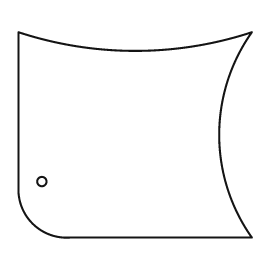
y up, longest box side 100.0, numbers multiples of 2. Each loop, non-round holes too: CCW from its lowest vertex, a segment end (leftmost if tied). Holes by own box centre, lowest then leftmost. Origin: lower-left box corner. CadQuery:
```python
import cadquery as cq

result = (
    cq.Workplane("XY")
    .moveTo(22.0, 0.0)
    .lineTo(100.0, 0.0)
    .threePointArc((86.0, 44.0), (100.0, 88.0))
    .threePointArc((50.0, 80.0), (0.0, 88.0))
    .lineTo(0.0, 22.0)
    .threePointArc((6.0, 6.0), (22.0, 0.0))
    .close()
    .moveTo(10.0, 24.0)
    .circle(2.0)
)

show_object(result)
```